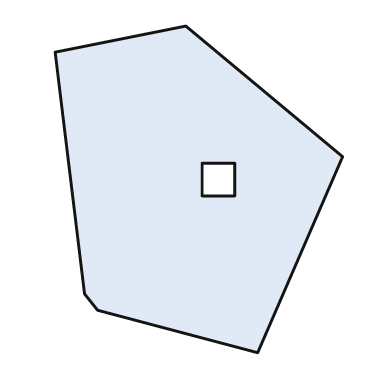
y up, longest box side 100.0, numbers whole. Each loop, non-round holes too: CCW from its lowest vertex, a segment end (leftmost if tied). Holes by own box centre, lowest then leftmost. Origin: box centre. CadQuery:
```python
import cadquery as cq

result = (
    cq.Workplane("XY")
    .moveTo(18.0, -50.0)
    .lineTo(44.0, 10.0)
    .lineTo(-4.0, 50.0)
    .lineTo(-44.0, 42.0)
    .lineTo(-35.0, -32.0)
    .lineTo(-31.0, -37.0)
    .close()
    .moveTo(1.0, -2.0)
    .lineTo(11.0, -2.0)
    .lineTo(11.0, 8.0)
    .lineTo(1.0, 8.0)
    .close()
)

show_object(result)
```